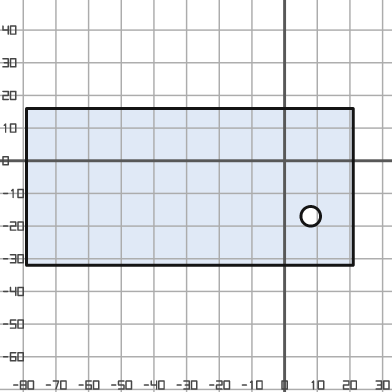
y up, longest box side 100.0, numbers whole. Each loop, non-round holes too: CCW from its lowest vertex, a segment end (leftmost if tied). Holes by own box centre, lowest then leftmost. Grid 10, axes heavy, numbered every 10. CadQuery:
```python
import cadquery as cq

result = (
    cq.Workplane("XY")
    .moveTo(-79.0, -32.0)
    .lineTo(21.0, -32.0)
    .lineTo(21.0, 16.0)
    .lineTo(-79.0, 16.0)
    .close()
    .moveTo(8.0, -17.0)
    .circle(3.0)
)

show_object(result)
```